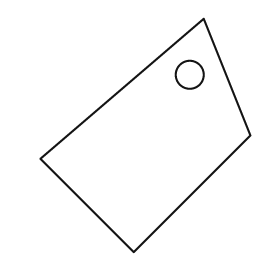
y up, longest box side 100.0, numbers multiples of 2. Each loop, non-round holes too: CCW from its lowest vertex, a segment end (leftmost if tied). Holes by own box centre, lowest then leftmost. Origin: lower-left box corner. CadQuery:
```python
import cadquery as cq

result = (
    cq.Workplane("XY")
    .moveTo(40.0, 0.0)
    .lineTo(90.0, 50.0)
    .lineTo(70.0, 100.0)
    .lineTo(0.0, 40.0)
    .close()
    .moveTo(64.0, 76.0)
    .circle(6.0)
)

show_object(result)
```